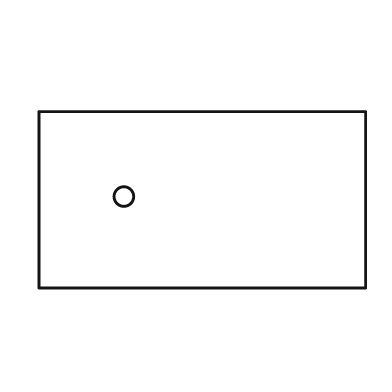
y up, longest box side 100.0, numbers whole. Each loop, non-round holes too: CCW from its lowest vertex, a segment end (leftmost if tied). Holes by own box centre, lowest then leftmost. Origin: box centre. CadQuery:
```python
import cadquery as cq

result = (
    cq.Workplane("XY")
    .moveTo(-50.0, -27.0)
    .lineTo(50.0, -27.0)
    .lineTo(50.0, 27.0)
    .lineTo(-50.0, 27.0)
    .close()
    .moveTo(-24.0, 1.0)
    .circle(3.0)
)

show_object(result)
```